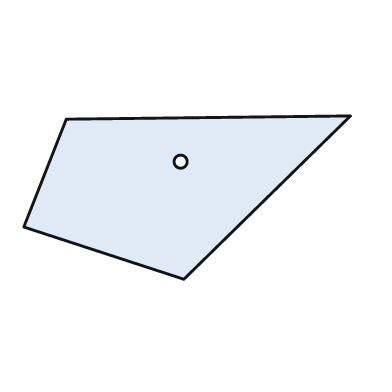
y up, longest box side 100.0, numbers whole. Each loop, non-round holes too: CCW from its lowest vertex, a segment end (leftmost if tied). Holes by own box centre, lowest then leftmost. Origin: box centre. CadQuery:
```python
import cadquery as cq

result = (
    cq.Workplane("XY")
    .moveTo(-1.0, -25.0)
    .lineTo(50.0, 25.0)
    .lineTo(-37.0, 24.0)
    .lineTo(-50.0, -9.0)
    .close()
    .moveTo(-2.0, 11.0)
    .circle(2.0)
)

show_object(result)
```